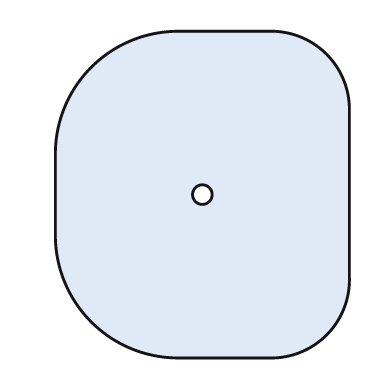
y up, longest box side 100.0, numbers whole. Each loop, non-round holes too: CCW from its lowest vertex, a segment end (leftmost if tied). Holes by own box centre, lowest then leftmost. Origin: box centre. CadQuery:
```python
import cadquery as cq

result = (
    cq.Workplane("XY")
    .moveTo(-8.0, -50.0)
    .lineTo(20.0, -50.0)
    .threePointArc((38.0, -43.0), (45.0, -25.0))
    .lineTo(45.0, 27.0)
    .threePointArc((38.0, 43.0), (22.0, 50.0))
    .lineTo(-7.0, 50.0)
    .threePointArc((-34.0, 39.0), (-45.0, 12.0))
    .lineTo(-45.0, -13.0)
    .threePointArc((-34.0, -39.0), (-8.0, -50.0))
    .close()
    .moveTo(0.0, 0.0)
    .circle(3.0)
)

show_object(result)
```